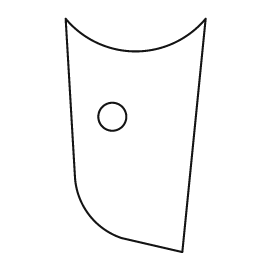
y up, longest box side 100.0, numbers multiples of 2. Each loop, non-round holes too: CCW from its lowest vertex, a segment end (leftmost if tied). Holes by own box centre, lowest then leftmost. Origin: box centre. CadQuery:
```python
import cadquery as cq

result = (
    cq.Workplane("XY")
    .moveTo(20.0, -50.0)
    .lineTo(30.0, 50.0)
    .threePointArc((0.0, 36.0), (-30.0, 50.0))
    .lineTo(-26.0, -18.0)
    .threePointArc((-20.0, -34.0), (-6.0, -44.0))
    .close()
    .moveTo(-10.0, 8.0)
    .circle(6.0)
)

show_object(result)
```